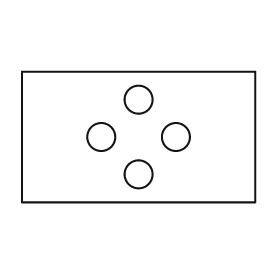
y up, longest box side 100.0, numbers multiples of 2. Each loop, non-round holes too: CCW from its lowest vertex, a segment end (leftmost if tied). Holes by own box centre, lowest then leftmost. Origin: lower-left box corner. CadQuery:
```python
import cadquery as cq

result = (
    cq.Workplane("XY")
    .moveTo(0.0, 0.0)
    .lineTo(100.0, 0.0)
    .lineTo(100.0, 56.0)
    .lineTo(0.0, 56.0)
    .close()
    .moveTo(50.0, 12.0)
    .circle(6.0)
    .moveTo(34.0, 28.0)
    .circle(6.0)
    .moveTo(66.0, 28.0)
    .circle(6.0)
    .moveTo(50.0, 44.0)
    .circle(6.0)
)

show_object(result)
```